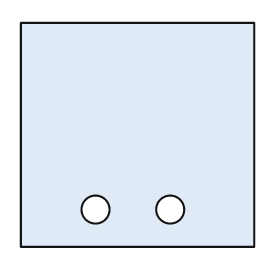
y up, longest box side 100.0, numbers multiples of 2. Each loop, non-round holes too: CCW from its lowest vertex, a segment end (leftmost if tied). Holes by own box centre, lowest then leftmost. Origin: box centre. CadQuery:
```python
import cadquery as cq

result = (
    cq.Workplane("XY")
    .moveTo(-50.0, -48.0)
    .lineTo(50.0, -48.0)
    .lineTo(50.0, 48.0)
    .lineTo(-50.0, 48.0)
    .close()
    .moveTo(-18.0, -32.0)
    .circle(6.0)
    .moveTo(14.0, -32.0)
    .circle(6.0)
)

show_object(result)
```